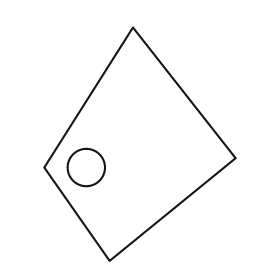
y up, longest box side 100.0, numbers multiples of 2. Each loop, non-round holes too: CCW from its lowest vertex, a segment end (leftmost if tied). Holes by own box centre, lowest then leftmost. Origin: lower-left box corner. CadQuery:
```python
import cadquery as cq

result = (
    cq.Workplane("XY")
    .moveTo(28.0, 0.0)
    .lineTo(82.0, 44.0)
    .lineTo(38.0, 100.0)
    .lineTo(0.0, 40.0)
    .close()
    .moveTo(18.0, 40.0)
    .circle(8.0)
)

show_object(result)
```